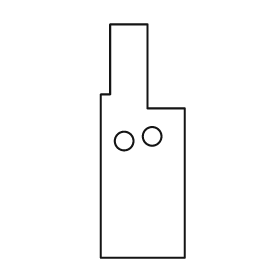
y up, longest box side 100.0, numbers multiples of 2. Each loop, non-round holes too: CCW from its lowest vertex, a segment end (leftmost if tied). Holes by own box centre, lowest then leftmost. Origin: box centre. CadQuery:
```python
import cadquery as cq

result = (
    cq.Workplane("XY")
    .moveTo(-18.0, -50.0)
    .lineTo(18.0, -50.0)
    .lineTo(18.0, 14.0)
    .lineTo(2.0, 14.0)
    .lineTo(2.0, 50.0)
    .lineTo(-14.0, 50.0)
    .lineTo(-14.0, 20.0)
    .lineTo(-18.0, 20.0)
    .close()
    .moveTo(-8.0, 0.0)
    .circle(4.0)
    .moveTo(4.0, 2.0)
    .circle(4.0)
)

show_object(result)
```